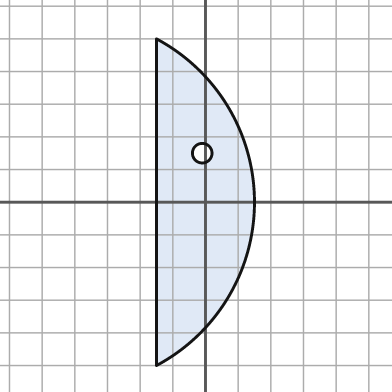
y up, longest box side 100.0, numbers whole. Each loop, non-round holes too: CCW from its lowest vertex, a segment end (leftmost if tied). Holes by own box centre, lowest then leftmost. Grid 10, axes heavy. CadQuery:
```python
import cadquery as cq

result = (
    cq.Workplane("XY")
    .moveTo(-15.0, -50.0)
    .threePointArc((15.0, 0.0), (-15.0, 50.0))
    .close()
    .moveTo(-1.0, 15.0)
    .circle(3.0)
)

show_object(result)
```